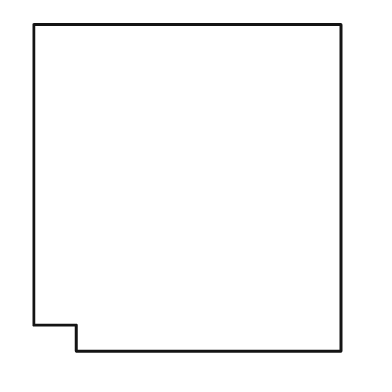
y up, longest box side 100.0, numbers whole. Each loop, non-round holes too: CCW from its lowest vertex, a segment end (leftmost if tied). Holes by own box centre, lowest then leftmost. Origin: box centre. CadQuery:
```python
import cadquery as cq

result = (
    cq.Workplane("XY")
    .moveTo(-34.0, -50.0)
    .lineTo(47.0, -50.0)
    .lineTo(47.0, 50.0)
    .lineTo(-47.0, 50.0)
    .lineTo(-47.0, -42.0)
    .lineTo(-34.0, -42.0)
    .close()
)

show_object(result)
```